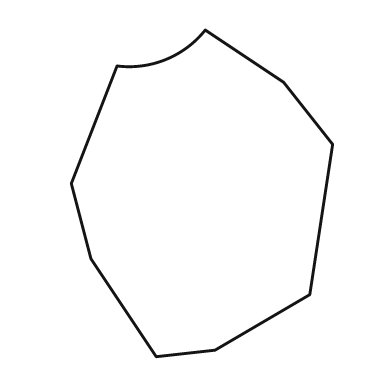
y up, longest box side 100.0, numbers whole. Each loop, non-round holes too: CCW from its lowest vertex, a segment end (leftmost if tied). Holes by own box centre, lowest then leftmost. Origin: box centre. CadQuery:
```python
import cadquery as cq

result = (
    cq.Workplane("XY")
    .moveTo(-14.0, -50.0)
    .lineTo(4.0, -48.0)
    .lineTo(33.0, -31.0)
    .lineTo(40.0, 15.0)
    .lineTo(25.0, 34.0)
    .lineTo(1.0, 50.0)
    .threePointArc((-11.0, 41.0), (-26.0, 39.0))
    .lineTo(-40.0, 3.0)
    .lineTo(-34.0, -20.0)
    .close()
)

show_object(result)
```